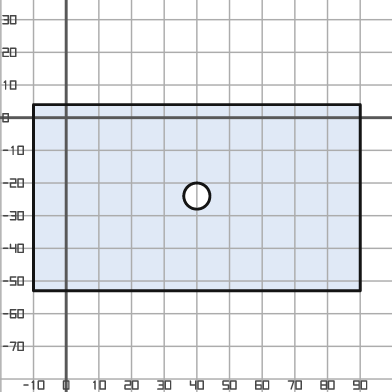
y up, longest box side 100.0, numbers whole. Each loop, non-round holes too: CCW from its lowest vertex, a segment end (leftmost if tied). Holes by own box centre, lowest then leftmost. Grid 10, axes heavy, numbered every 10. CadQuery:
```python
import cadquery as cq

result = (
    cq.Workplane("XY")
    .moveTo(-10.0, -53.0)
    .lineTo(90.0, -53.0)
    .lineTo(90.0, 4.0)
    .lineTo(-10.0, 4.0)
    .close()
    .moveTo(40.0, -24.0)
    .circle(4.0)
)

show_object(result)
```